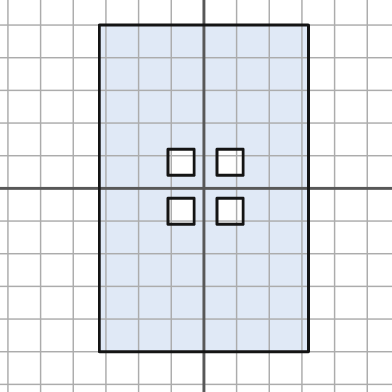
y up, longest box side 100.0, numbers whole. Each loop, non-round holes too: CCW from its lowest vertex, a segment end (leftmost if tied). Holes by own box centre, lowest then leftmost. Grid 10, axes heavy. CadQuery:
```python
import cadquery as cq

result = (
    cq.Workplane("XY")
    .moveTo(-32.0, -50.0)
    .lineTo(32.0, -50.0)
    .lineTo(32.0, 50.0)
    .lineTo(-32.0, 50.0)
    .close()
    .moveTo(-11.0, -11.0)
    .lineTo(-3.0, -11.0)
    .lineTo(-3.0, -3.0)
    .lineTo(-11.0, -3.0)
    .close()
    .moveTo(4.0, -11.0)
    .lineTo(12.0, -11.0)
    .lineTo(12.0, -3.0)
    .lineTo(4.0, -3.0)
    .close()
    .moveTo(-11.0, 4.0)
    .lineTo(-3.0, 4.0)
    .lineTo(-3.0, 12.0)
    .lineTo(-11.0, 12.0)
    .close()
    .moveTo(4.0, 4.0)
    .lineTo(12.0, 4.0)
    .lineTo(12.0, 12.0)
    .lineTo(4.0, 12.0)
    .close()
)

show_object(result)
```